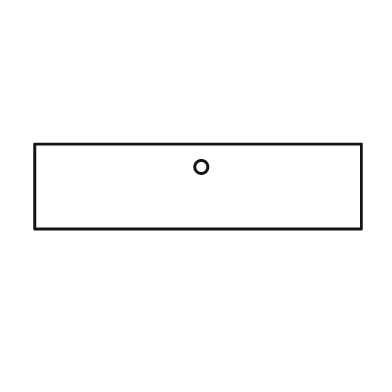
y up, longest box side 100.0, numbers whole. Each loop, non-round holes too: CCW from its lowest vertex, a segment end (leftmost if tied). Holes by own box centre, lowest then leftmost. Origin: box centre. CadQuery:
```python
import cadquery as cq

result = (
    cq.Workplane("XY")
    .moveTo(-50.0, -13.0)
    .lineTo(50.0, -13.0)
    .lineTo(50.0, 13.0)
    .lineTo(-50.0, 13.0)
    .close()
    .moveTo(1.0, 6.0)
    .circle(2.0)
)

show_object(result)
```